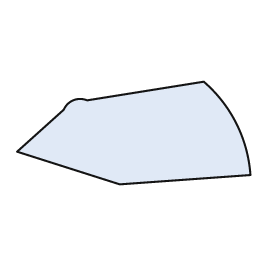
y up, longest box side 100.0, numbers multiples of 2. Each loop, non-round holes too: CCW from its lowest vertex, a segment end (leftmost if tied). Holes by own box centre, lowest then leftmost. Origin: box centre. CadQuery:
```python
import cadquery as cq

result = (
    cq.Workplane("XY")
    .moveTo(-6.0, -22.0)
    .lineTo(50.0, -18.0)
    .threePointArc((44.0, 4.0), (30.0, 22.0))
    .lineTo(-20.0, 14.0)
    .threePointArc((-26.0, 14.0), (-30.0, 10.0))
    .lineTo(-50.0, -8.0)
    .close()
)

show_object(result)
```